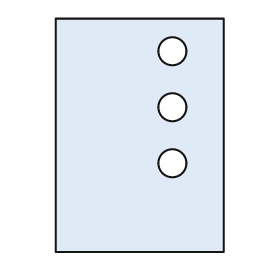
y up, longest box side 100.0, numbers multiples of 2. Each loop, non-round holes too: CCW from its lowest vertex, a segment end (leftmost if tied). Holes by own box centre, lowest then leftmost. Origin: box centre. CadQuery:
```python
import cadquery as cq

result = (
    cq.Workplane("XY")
    .moveTo(-36.0, -50.0)
    .lineTo(36.0, -50.0)
    .lineTo(36.0, 50.0)
    .lineTo(-36.0, 50.0)
    .close()
    .moveTo(14.0, -12.0)
    .circle(6.0)
    .moveTo(14.0, 12.0)
    .circle(6.0)
    .moveTo(14.0, 36.0)
    .circle(6.0)
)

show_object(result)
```